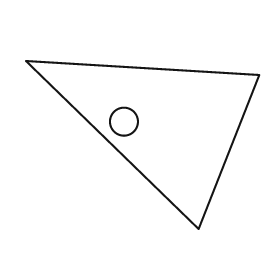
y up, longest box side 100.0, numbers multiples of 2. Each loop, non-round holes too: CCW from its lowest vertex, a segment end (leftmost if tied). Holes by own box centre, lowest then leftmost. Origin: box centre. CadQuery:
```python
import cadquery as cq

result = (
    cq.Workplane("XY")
    .moveTo(24.0, -36.0)
    .lineTo(50.0, 30.0)
    .lineTo(-50.0, 36.0)
    .close()
    .moveTo(-8.0, 10.0)
    .circle(6.0)
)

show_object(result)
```